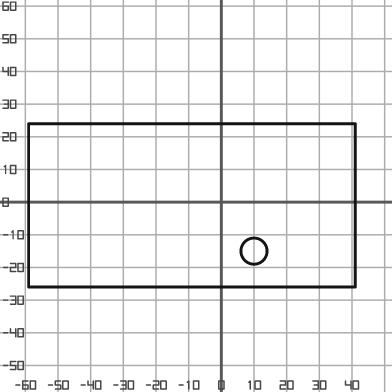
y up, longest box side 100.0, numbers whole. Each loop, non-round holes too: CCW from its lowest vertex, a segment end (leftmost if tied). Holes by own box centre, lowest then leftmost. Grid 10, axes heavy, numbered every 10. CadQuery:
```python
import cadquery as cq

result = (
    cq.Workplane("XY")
    .moveTo(-59.0, -26.0)
    .lineTo(41.0, -26.0)
    .lineTo(41.0, 24.0)
    .lineTo(-59.0, 24.0)
    .close()
    .moveTo(10.0, -15.0)
    .circle(4.0)
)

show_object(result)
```